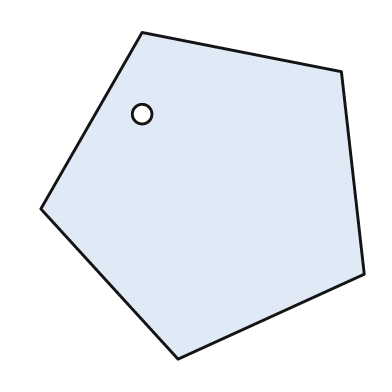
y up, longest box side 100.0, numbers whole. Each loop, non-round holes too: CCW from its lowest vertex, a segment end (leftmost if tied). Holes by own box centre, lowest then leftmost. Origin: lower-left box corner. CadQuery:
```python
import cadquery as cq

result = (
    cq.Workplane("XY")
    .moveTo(42.0, 0.0)
    .lineTo(99.0, 26.0)
    .lineTo(92.0, 88.0)
    .lineTo(31.0, 100.0)
    .lineTo(0.0, 46.0)
    .close()
    .moveTo(31.0, 75.0)
    .circle(3.0)
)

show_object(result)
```